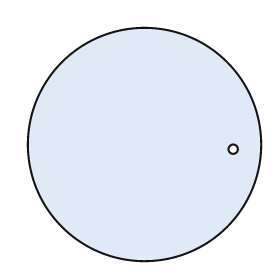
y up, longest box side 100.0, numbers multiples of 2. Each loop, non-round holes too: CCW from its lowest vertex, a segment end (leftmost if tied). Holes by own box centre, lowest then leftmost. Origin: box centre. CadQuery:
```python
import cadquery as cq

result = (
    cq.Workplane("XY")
    .moveTo(0.0, 0.0)
    .circle(50.0)
    .moveTo(38.0, -2.0)
    .circle(2.0)
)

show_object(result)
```